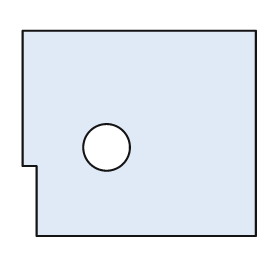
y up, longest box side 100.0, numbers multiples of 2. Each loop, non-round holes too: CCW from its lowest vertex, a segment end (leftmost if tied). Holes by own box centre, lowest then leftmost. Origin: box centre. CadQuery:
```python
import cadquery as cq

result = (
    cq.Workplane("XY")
    .moveTo(-44.0, -44.0)
    .lineTo(50.0, -44.0)
    .lineTo(50.0, 44.0)
    .lineTo(-50.0, 44.0)
    .lineTo(-50.0, -14.0)
    .lineTo(-44.0, -14.0)
    .close()
    .moveTo(-14.0, -6.0)
    .circle(10.0)
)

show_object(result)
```